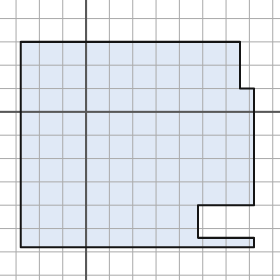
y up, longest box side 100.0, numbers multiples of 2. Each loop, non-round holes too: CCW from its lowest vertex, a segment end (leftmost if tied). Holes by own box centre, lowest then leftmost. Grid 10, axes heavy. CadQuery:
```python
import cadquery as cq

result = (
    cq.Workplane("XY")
    .moveTo(-28.0, -58.0)
    .lineTo(72.0, -58.0)
    .lineTo(72.0, -54.0)
    .lineTo(48.0, -54.0)
    .lineTo(48.0, -40.0)
    .lineTo(72.0, -40.0)
    .lineTo(72.0, 10.0)
    .lineTo(66.0, 10.0)
    .lineTo(66.0, 30.0)
    .lineTo(-28.0, 30.0)
    .close()
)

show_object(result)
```